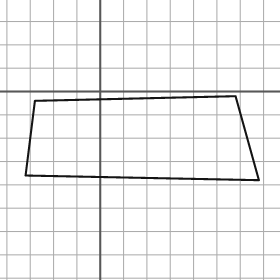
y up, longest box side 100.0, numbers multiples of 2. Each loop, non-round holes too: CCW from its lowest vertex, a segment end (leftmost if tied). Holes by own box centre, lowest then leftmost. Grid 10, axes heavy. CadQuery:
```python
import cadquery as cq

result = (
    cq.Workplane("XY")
    .moveTo(68.0, -38.0)
    .lineTo(58.0, -2.0)
    .lineTo(-28.0, -4.0)
    .lineTo(-32.0, -36.0)
    .close()
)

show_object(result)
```